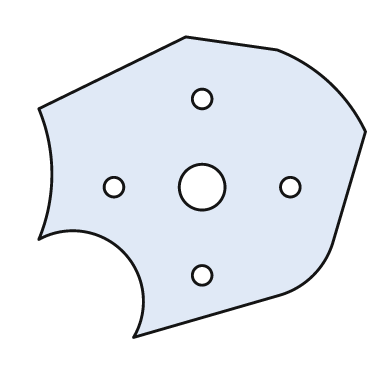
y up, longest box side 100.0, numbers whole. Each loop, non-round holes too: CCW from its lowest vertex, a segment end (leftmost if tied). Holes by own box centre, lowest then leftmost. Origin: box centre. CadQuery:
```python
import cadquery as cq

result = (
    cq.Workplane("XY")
    .moveTo(-21.0, -46.0)
    .lineTo(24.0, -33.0)
    .threePointArc((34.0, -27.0), (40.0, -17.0))
    .lineTo(50.0, 17.0)
    .threePointArc((39.0, 32.0), (23.0, 42.0))
    .lineTo(-5.0, 46.0)
    .lineTo(-50.0, 24.0)
    .threePointArc((-46.0, 4.0), (-50.0, -16.0))
    .threePointArc((-24.0, -20.0), (-21.0, -46.0))
    .close()
    .moveTo(0.0, -27.0)
    .circle(3.0)
    .moveTo(-27.0, 0.0)
    .circle(3.0)
    .moveTo(0.0, 0.0)
    .circle(7.0)
    .moveTo(27.0, 0.0)
    .circle(3.0)
    .moveTo(0.0, 27.0)
    .circle(3.0)
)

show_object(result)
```